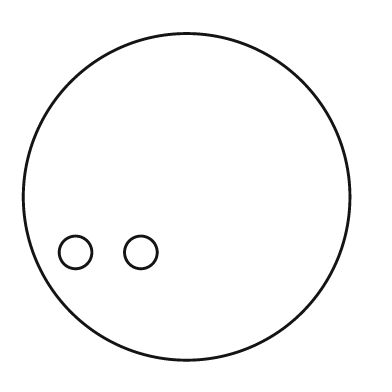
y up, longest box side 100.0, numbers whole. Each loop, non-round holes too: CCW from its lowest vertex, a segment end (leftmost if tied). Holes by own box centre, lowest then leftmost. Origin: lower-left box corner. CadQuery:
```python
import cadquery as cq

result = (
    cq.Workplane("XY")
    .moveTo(50.0, 50.0)
    .circle(50.0)
    .moveTo(16.0, 33.0)
    .circle(5.0)
    .moveTo(36.0, 33.0)
    .circle(5.0)
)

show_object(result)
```